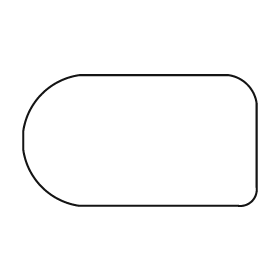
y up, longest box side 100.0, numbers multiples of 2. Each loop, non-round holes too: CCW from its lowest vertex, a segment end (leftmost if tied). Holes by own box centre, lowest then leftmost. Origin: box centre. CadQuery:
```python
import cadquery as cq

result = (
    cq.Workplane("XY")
    .moveTo(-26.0, -28.0)
    .lineTo(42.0, -28.0)
    .threePointArc((48.0, -26.0), (50.0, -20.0))
    .lineTo(50.0, 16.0)
    .threePointArc((46.0, 24.0), (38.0, 28.0))
    .lineTo(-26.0, 28.0)
    .threePointArc((-42.0, 20.0), (-50.0, 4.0))
    .lineTo(-50.0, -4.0)
    .threePointArc((-42.0, -20.0), (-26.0, -28.0))
    .close()
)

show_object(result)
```